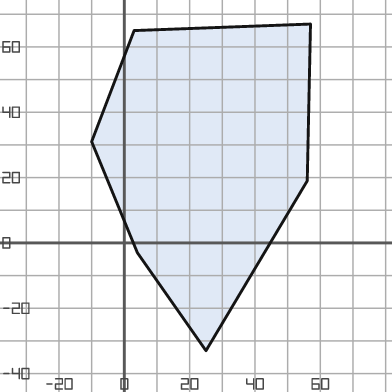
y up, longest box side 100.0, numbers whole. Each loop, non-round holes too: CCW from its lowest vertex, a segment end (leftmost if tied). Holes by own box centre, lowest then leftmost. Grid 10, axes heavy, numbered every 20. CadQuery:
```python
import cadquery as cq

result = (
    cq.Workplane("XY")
    .moveTo(25.0, -33.0)
    .lineTo(56.0, 19.0)
    .lineTo(57.0, 67.0)
    .lineTo(3.0, 65.0)
    .lineTo(-10.0, 31.0)
    .lineTo(4.0, -3.0)
    .close()
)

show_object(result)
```